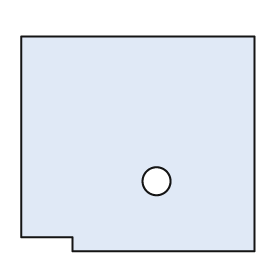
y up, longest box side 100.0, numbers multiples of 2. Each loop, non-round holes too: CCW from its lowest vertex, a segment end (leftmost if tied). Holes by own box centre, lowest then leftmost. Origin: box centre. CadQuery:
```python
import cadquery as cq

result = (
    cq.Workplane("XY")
    .moveTo(-28.0, -46.0)
    .lineTo(50.0, -46.0)
    .lineTo(50.0, 46.0)
    .lineTo(-50.0, 46.0)
    .lineTo(-50.0, -40.0)
    .lineTo(-28.0, -40.0)
    .close()
    .moveTo(8.0, -16.0)
    .circle(6.0)
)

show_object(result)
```